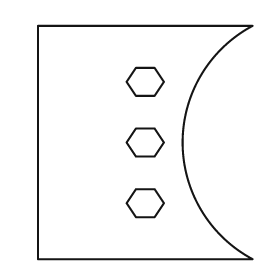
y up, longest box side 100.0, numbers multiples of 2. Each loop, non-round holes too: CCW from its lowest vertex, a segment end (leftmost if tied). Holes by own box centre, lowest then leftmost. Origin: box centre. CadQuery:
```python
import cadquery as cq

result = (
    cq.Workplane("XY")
    .moveTo(-46.0, -50.0)
    .lineTo(46.0, -50.0)
    .threePointArc((16.0, 0.0), (46.0, 50.0))
    .lineTo(-46.0, 50.0)
    .close()
    .moveTo(-4.0, -32.0)
    .lineTo(4.0, -32.0)
    .lineTo(8.0, -26.0)
    .lineTo(4.0, -20.0)
    .lineTo(-4.0, -20.0)
    .lineTo(-8.0, -26.0)
    .close()
    .moveTo(-4.0, -6.0)
    .lineTo(4.0, -6.0)
    .lineTo(8.0, 0.0)
    .lineTo(4.0, 6.0)
    .lineTo(-4.0, 6.0)
    .lineTo(-8.0, 0.0)
    .close()
    .moveTo(-4.0, 20.0)
    .lineTo(4.0, 20.0)
    .lineTo(8.0, 26.0)
    .lineTo(4.0, 32.0)
    .lineTo(-4.0, 32.0)
    .lineTo(-8.0, 26.0)
    .close()
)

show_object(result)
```